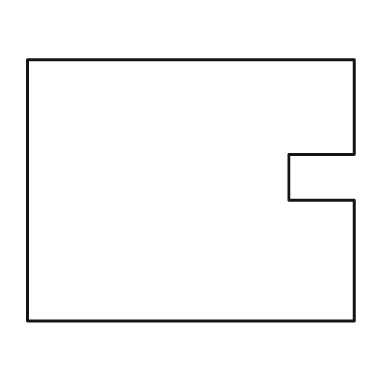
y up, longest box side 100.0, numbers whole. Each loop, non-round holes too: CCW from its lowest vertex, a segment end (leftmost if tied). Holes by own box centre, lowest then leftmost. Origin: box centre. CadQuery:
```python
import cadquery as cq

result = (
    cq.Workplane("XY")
    .moveTo(-50.0, -40.0)
    .lineTo(50.0, -40.0)
    .lineTo(50.0, -3.0)
    .lineTo(30.0, -3.0)
    .lineTo(30.0, 11.0)
    .lineTo(50.0, 11.0)
    .lineTo(50.0, 40.0)
    .lineTo(-50.0, 40.0)
    .close()
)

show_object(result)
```